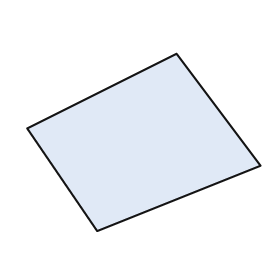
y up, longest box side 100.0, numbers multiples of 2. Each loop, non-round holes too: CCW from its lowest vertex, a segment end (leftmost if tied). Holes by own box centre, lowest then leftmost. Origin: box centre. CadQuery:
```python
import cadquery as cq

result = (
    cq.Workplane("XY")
    .moveTo(-20.0, -38.0)
    .lineTo(50.0, -10.0)
    .lineTo(14.0, 38.0)
    .lineTo(-50.0, 6.0)
    .close()
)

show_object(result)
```